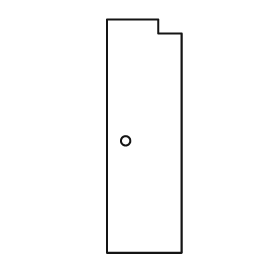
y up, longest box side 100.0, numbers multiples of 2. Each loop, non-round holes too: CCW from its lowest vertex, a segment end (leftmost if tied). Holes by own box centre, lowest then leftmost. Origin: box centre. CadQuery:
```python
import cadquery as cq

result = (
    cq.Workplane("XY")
    .moveTo(-16.0, -50.0)
    .lineTo(16.0, -50.0)
    .lineTo(16.0, 44.0)
    .lineTo(6.0, 44.0)
    .lineTo(6.0, 50.0)
    .lineTo(-16.0, 50.0)
    .close()
    .moveTo(-8.0, -2.0)
    .circle(2.0)
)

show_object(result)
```